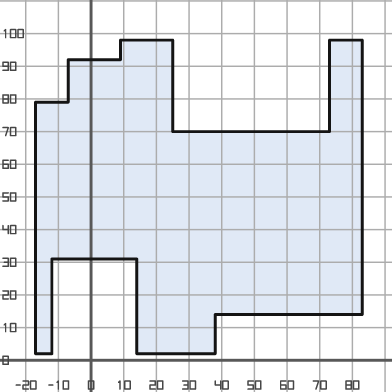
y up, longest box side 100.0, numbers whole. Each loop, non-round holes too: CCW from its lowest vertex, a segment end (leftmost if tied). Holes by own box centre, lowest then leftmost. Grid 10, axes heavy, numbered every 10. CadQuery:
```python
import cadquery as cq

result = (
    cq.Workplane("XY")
    .moveTo(-17.0, 2.0)
    .lineTo(-12.0, 2.0)
    .lineTo(-12.0, 31.0)
    .lineTo(14.0, 31.0)
    .lineTo(14.0, 2.0)
    .lineTo(38.0, 2.0)
    .lineTo(38.0, 14.0)
    .lineTo(83.0, 14.0)
    .lineTo(83.0, 98.0)
    .lineTo(73.0, 98.0)
    .lineTo(73.0, 70.0)
    .lineTo(25.0, 70.0)
    .lineTo(25.0, 98.0)
    .lineTo(9.0, 98.0)
    .lineTo(9.0, 92.0)
    .lineTo(-7.0, 92.0)
    .lineTo(-7.0, 79.0)
    .lineTo(-17.0, 79.0)
    .close()
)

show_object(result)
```